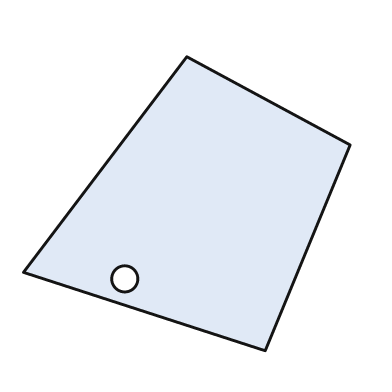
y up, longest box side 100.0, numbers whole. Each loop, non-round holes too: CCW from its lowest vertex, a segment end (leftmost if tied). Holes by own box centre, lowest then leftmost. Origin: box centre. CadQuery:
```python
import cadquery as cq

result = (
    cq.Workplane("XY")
    .moveTo(24.0, -45.0)
    .lineTo(50.0, 18.0)
    .lineTo(0.0, 45.0)
    .lineTo(-50.0, -21.0)
    .close()
    .moveTo(-19.0, -23.0)
    .circle(4.0)
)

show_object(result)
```